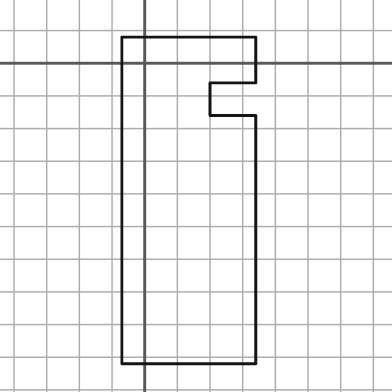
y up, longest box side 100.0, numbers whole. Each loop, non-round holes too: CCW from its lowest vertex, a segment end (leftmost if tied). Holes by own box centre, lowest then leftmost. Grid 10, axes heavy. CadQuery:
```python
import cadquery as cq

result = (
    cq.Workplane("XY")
    .moveTo(-7.0, -92.0)
    .lineTo(34.0, -92.0)
    .lineTo(34.0, -16.0)
    .lineTo(20.0, -16.0)
    .lineTo(20.0, -6.0)
    .lineTo(34.0, -6.0)
    .lineTo(34.0, 8.0)
    .lineTo(-7.0, 8.0)
    .close()
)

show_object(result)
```